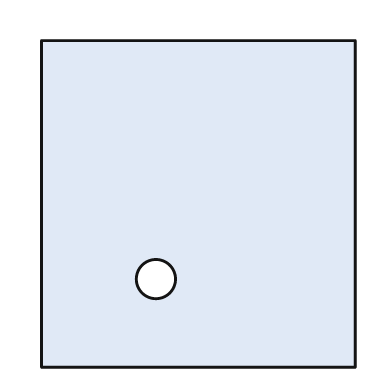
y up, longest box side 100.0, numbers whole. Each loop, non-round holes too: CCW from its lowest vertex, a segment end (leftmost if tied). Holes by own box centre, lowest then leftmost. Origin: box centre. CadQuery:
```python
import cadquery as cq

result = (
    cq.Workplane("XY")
    .moveTo(-48.0, -50.0)
    .lineTo(48.0, -50.0)
    .lineTo(48.0, 50.0)
    .lineTo(-48.0, 50.0)
    .close()
    .moveTo(-13.0, -23.0)
    .circle(6.0)
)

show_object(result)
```